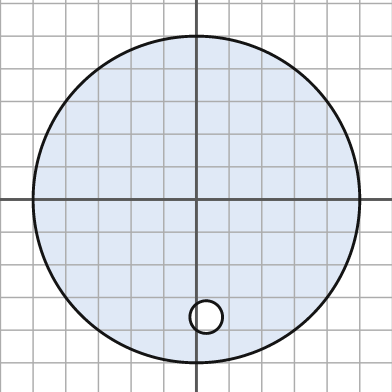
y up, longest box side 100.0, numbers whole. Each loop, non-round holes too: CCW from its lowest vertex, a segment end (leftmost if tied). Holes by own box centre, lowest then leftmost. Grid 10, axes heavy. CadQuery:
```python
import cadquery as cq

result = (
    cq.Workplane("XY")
    .moveTo(0.0, 0.0)
    .circle(50.0)
    .moveTo(3.0, -36.0)
    .circle(5.0)
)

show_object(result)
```